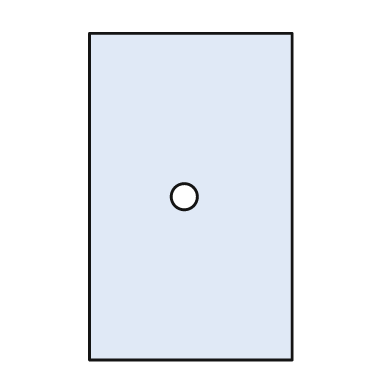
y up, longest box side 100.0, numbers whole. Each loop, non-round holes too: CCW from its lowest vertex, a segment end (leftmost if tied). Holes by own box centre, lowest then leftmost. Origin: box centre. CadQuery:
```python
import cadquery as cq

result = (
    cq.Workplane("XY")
    .moveTo(-31.0, -50.0)
    .lineTo(31.0, -50.0)
    .lineTo(31.0, 50.0)
    .lineTo(-31.0, 50.0)
    .close()
    .moveTo(-2.0, 0.0)
    .circle(4.0)
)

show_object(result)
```